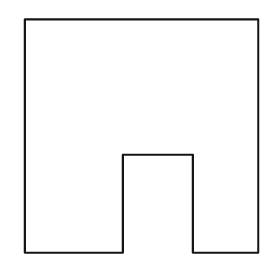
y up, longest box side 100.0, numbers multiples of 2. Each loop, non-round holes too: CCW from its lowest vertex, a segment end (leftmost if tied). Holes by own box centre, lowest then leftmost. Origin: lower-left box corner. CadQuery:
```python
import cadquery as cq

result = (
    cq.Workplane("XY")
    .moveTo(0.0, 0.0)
    .lineTo(42.0, 0.0)
    .lineTo(42.0, 42.0)
    .lineTo(72.0, 42.0)
    .lineTo(72.0, 0.0)
    .lineTo(100.0, 0.0)
    .lineTo(100.0, 100.0)
    .lineTo(0.0, 100.0)
    .close()
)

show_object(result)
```